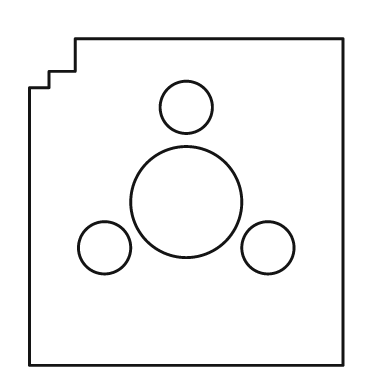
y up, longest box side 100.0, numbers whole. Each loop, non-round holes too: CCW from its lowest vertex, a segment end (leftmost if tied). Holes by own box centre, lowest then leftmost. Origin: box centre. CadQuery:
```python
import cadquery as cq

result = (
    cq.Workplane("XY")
    .moveTo(-48.0, -50.0)
    .lineTo(48.0, -50.0)
    .lineTo(48.0, 50.0)
    .lineTo(-34.0, 50.0)
    .lineTo(-34.0, 40.0)
    .lineTo(-42.0, 40.0)
    .lineTo(-42.0, 35.0)
    .lineTo(-48.0, 35.0)
    .close()
    .moveTo(-25.0, -14.0)
    .circle(8.0)
    .moveTo(25.0, -14.0)
    .circle(8.0)
    .moveTo(0.0, 0.0)
    .circle(17.0)
    .moveTo(0.0, 29.0)
    .circle(8.0)
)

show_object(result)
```